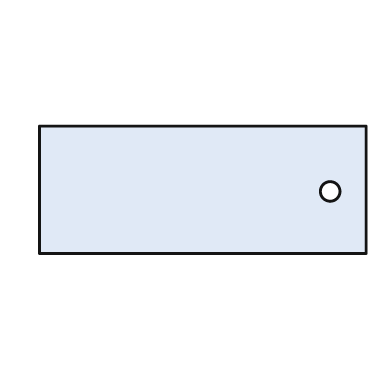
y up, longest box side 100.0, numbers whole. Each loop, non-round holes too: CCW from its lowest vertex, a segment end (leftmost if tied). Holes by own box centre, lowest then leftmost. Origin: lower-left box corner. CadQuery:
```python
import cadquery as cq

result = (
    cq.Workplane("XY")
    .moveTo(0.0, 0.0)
    .lineTo(100.0, 0.0)
    .lineTo(100.0, 39.0)
    .lineTo(0.0, 39.0)
    .close()
    .moveTo(89.0, 19.0)
    .circle(3.0)
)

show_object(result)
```